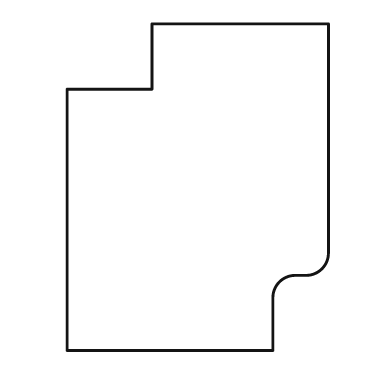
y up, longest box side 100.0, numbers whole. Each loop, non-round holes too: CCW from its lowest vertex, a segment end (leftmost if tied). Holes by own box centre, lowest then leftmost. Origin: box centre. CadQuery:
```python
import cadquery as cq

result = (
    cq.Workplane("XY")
    .moveTo(-40.0, -50.0)
    .lineTo(23.0, -50.0)
    .lineTo(23.0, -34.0)
    .threePointArc((25.0, -29.0), (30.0, -27.0))
    .lineTo(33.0, -27.0)
    .threePointArc((38.0, -25.0), (40.0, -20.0))
    .lineTo(40.0, 50.0)
    .lineTo(-14.0, 50.0)
    .lineTo(-14.0, 30.0)
    .lineTo(-40.0, 30.0)
    .close()
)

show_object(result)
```